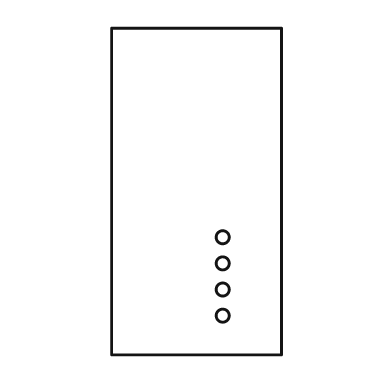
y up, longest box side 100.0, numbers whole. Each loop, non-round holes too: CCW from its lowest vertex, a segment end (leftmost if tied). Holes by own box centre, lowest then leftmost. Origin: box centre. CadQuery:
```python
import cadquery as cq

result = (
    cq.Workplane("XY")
    .moveTo(-26.0, -50.0)
    .lineTo(26.0, -50.0)
    .lineTo(26.0, 50.0)
    .lineTo(-26.0, 50.0)
    .close()
    .moveTo(8.0, -38.0)
    .circle(2.0)
    .moveTo(8.0, -30.0)
    .circle(2.0)
    .moveTo(8.0, -22.0)
    .circle(2.0)
    .moveTo(8.0, -14.0)
    .circle(2.0)
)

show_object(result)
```